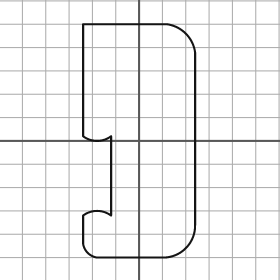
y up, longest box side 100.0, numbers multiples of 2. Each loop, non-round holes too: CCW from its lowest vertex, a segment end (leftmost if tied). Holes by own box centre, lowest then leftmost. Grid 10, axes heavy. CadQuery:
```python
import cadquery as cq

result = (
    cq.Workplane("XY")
    .moveTo(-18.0, -50.0)
    .lineTo(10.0, -50.0)
    .threePointArc((20.0, -46.0), (24.0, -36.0))
    .lineTo(24.0, 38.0)
    .threePointArc((20.0, 46.0), (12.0, 50.0))
    .lineTo(-24.0, 50.0)
    .lineTo(-24.0, 2.0)
    .threePointArc((-18.0, 0.0), (-12.0, 2.0))
    .lineTo(-12.0, -32.0)
    .threePointArc((-18.0, -30.0), (-24.0, -32.0))
    .lineTo(-24.0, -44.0)
    .threePointArc((-22.0, -48.0), (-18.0, -50.0))
    .close()
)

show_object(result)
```